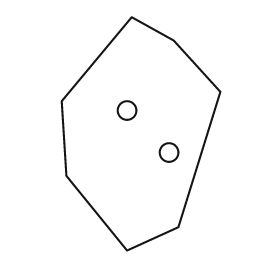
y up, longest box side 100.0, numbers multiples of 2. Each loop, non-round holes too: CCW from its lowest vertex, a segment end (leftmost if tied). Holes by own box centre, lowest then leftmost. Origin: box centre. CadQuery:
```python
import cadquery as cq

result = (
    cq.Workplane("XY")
    .moveTo(-6.0, -50.0)
    .lineTo(16.0, -40.0)
    .lineTo(34.0, 18.0)
    .lineTo(14.0, 40.0)
    .lineTo(-4.0, 50.0)
    .lineTo(-34.0, 14.0)
    .lineTo(-32.0, -18.0)
    .close()
    .moveTo(12.0, -8.0)
    .circle(4.0)
    .moveTo(-6.0, 10.0)
    .circle(4.0)
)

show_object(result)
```